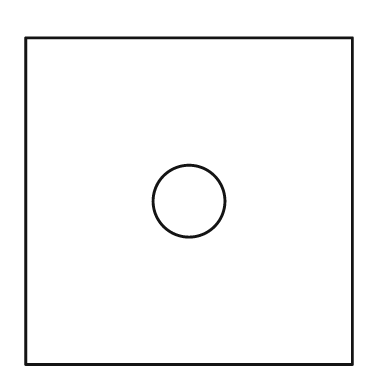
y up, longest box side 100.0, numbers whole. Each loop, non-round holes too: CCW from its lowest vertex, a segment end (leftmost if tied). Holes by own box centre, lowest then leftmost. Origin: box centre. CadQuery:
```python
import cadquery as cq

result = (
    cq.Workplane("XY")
    .moveTo(-50.0, -50.0)
    .lineTo(50.0, -50.0)
    .lineTo(50.0, 50.0)
    .lineTo(-50.0, 50.0)
    .close()
    .moveTo(0.0, 0.0)
    .circle(11.0)
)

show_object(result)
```